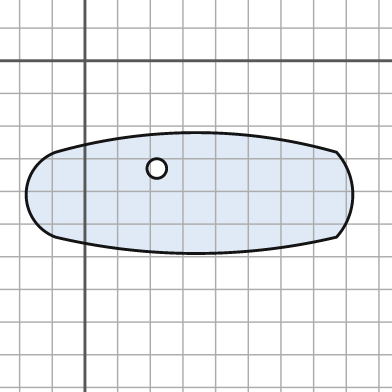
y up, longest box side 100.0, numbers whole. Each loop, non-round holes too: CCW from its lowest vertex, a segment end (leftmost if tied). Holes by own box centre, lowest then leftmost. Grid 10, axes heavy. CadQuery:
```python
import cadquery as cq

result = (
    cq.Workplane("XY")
    .moveTo(-9.0, -54.0)
    .threePointArc((34.0, -59.0), (77.0, -54.0))
    .threePointArc((82.0, -41.0), (77.0, -28.0))
    .threePointArc((34.0, -22.0), (-9.0, -28.0))
    .threePointArc((-18.0, -41.0), (-9.0, -54.0))
    .close()
    .moveTo(22.0, -33.0)
    .circle(3.0)
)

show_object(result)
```